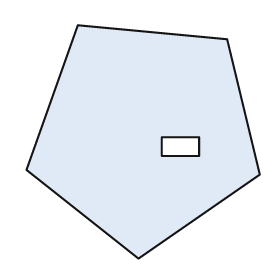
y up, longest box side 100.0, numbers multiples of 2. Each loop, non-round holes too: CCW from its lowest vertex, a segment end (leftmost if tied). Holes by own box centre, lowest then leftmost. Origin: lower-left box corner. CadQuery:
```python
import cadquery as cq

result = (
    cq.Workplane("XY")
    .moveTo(48.0, 0.0)
    .lineTo(100.0, 36.0)
    .lineTo(86.0, 94.0)
    .lineTo(22.0, 100.0)
    .lineTo(0.0, 38.0)
    .close()
    .moveTo(58.0, 44.0)
    .lineTo(74.0, 44.0)
    .lineTo(74.0, 52.0)
    .lineTo(58.0, 52.0)
    .close()
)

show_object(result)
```